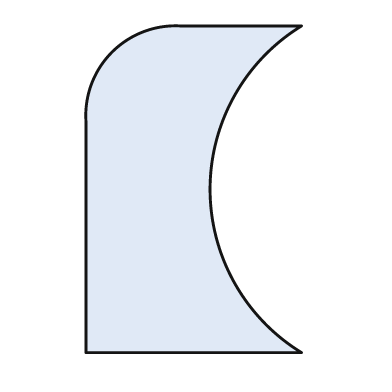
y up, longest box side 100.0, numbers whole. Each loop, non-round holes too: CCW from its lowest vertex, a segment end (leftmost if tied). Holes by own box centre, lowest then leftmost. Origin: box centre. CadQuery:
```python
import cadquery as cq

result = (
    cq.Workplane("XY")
    .moveTo(-33.0, -50.0)
    .lineTo(33.0, -50.0)
    .threePointArc((5.0, 0.0), (33.0, 50.0))
    .lineTo(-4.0, 50.0)
    .threePointArc((-25.0, 42.0), (-33.0, 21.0))
    .close()
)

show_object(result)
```